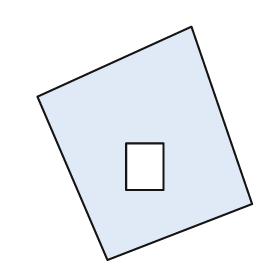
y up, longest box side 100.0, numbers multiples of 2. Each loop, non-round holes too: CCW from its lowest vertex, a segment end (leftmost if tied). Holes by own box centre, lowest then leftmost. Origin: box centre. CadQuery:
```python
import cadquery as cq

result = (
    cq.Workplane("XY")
    .moveTo(-16.0, -50.0)
    .lineTo(46.0, -26.0)
    .lineTo(20.0, 50.0)
    .lineTo(-46.0, 20.0)
    .close()
    .moveTo(-8.0, -20.0)
    .lineTo(8.0, -20.0)
    .lineTo(8.0, 0.0)
    .lineTo(-8.0, 0.0)
    .close()
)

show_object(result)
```